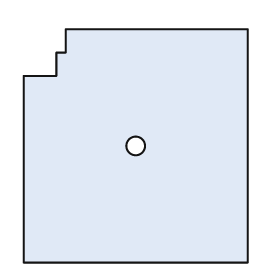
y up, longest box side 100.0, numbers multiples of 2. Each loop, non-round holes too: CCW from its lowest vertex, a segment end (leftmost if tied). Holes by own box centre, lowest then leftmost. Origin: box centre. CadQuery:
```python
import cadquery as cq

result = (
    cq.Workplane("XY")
    .moveTo(-48.0, -50.0)
    .lineTo(48.0, -50.0)
    .lineTo(48.0, 50.0)
    .lineTo(-30.0, 50.0)
    .lineTo(-30.0, 40.0)
    .lineTo(-34.0, 40.0)
    .lineTo(-34.0, 30.0)
    .lineTo(-48.0, 30.0)
    .close()
    .moveTo(0.0, 0.0)
    .circle(4.0)
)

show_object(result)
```